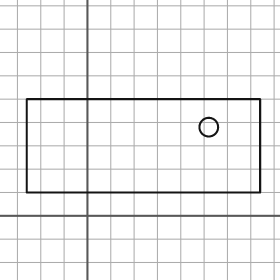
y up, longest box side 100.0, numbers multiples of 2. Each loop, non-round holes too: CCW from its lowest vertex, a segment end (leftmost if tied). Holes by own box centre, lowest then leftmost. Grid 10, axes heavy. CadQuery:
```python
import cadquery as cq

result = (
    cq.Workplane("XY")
    .moveTo(-26.0, 10.0)
    .lineTo(74.0, 10.0)
    .lineTo(74.0, 50.0)
    .lineTo(-26.0, 50.0)
    .close()
    .moveTo(52.0, 38.0)
    .circle(4.0)
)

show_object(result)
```